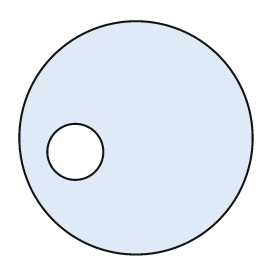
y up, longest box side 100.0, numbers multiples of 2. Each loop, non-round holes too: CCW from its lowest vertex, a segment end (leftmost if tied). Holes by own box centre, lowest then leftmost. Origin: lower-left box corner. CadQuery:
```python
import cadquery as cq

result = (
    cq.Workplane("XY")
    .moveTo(50.0, 50.0)
    .circle(50.0)
    .moveTo(24.0, 44.0)
    .circle(12.0)
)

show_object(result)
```